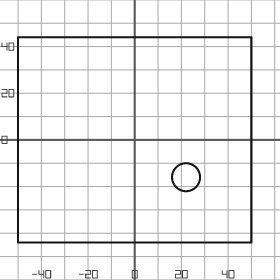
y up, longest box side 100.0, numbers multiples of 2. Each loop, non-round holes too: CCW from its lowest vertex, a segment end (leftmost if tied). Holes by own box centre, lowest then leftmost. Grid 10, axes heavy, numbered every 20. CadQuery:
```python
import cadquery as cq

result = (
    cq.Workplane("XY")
    .moveTo(-50.0, -44.0)
    .lineTo(50.0, -44.0)
    .lineTo(50.0, 44.0)
    .lineTo(-50.0, 44.0)
    .close()
    .moveTo(22.0, -16.0)
    .circle(6.0)
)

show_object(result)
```